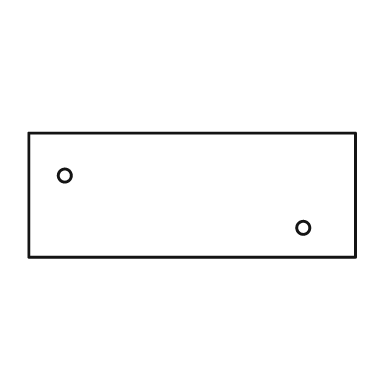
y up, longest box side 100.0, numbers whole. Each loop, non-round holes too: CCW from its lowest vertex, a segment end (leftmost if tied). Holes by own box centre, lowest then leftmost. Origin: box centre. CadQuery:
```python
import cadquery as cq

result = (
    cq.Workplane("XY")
    .moveTo(-50.0, -19.0)
    .lineTo(50.0, -19.0)
    .lineTo(50.0, 19.0)
    .lineTo(-50.0, 19.0)
    .close()
    .moveTo(34.0, -10.0)
    .circle(2.0)
    .moveTo(-39.0, 6.0)
    .circle(2.0)
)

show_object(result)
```